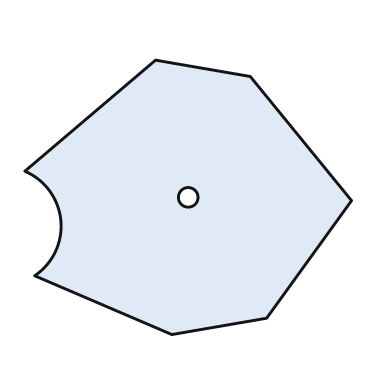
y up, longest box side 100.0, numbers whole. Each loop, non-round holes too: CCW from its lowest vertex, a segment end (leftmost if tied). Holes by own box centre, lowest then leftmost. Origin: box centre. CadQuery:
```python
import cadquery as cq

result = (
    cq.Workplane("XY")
    .moveTo(-5.0, -42.0)
    .lineTo(24.0, -37.0)
    .lineTo(50.0, -1.0)
    .lineTo(19.0, 37.0)
    .lineTo(-10.0, 42.0)
    .lineTo(-50.0, 8.0)
    .threePointArc((-39.0, -7.0), (-47.0, -24.0))
    .close()
    .moveTo(0.0, 0.0)
    .circle(3.0)
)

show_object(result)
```